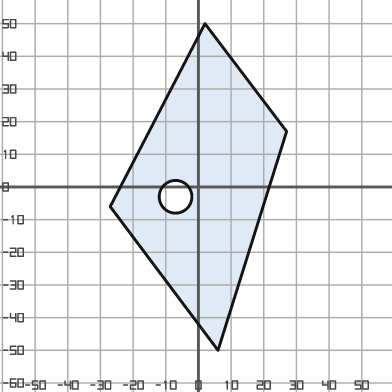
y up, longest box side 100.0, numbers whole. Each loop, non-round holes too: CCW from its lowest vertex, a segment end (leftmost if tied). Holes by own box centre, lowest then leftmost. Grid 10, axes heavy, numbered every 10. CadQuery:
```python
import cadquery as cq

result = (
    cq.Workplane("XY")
    .moveTo(6.0, -50.0)
    .lineTo(27.0, 17.0)
    .lineTo(2.0, 50.0)
    .lineTo(-27.0, -6.0)
    .close()
    .moveTo(-7.0, -3.0)
    .circle(5.0)
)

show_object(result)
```